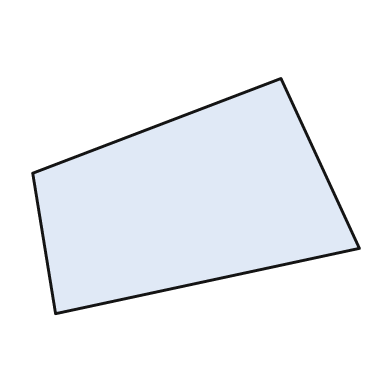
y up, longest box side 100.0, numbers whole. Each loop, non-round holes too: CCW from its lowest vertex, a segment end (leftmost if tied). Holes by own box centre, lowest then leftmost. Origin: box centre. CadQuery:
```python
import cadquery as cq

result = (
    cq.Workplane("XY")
    .moveTo(-43.0, -36.0)
    .lineTo(50.0, -16.0)
    .lineTo(26.0, 36.0)
    .lineTo(-50.0, 7.0)
    .close()
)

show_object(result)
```